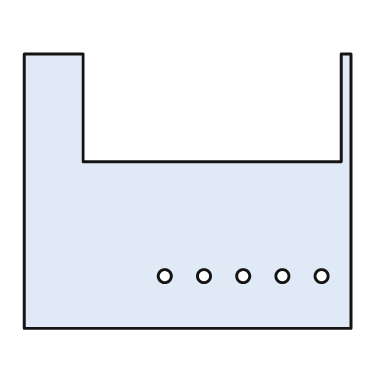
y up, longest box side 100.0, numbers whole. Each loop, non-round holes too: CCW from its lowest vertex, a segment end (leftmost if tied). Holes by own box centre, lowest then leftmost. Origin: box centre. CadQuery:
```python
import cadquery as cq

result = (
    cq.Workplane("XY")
    .moveTo(-50.0, -42.0)
    .lineTo(50.0, -42.0)
    .lineTo(50.0, 42.0)
    .lineTo(47.0, 42.0)
    .lineTo(47.0, 9.0)
    .lineTo(-32.0, 9.0)
    .lineTo(-32.0, 42.0)
    .lineTo(-50.0, 42.0)
    .close()
    .moveTo(-7.0, -26.0)
    .circle(2.0)
    .moveTo(5.0, -26.0)
    .circle(2.0)
    .moveTo(17.0, -26.0)
    .circle(2.0)
    .moveTo(29.0, -26.0)
    .circle(2.0)
    .moveTo(41.0, -26.0)
    .circle(2.0)
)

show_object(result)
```